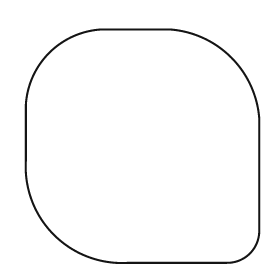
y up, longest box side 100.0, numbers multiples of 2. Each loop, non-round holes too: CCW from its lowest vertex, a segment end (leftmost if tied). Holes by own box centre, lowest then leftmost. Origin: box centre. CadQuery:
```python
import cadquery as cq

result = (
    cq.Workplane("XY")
    .moveTo(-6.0, -50.0)
    .lineTo(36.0, -50.0)
    .threePointArc((46.0, -46.0), (50.0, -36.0))
    .lineTo(50.0, 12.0)
    .threePointArc((38.0, 38.0), (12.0, 50.0))
    .lineTo(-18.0, 50.0)
    .threePointArc((-40.0, 40.0), (-50.0, 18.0))
    .lineTo(-50.0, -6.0)
    .threePointArc((-38.0, -38.0), (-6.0, -50.0))
    .close()
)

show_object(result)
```